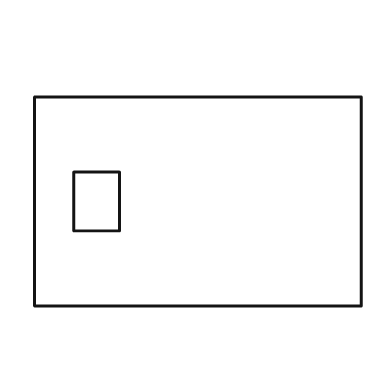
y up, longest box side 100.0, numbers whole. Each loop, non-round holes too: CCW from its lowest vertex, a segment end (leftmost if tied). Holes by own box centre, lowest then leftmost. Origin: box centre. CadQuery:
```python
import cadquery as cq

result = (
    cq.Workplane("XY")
    .moveTo(-50.0, -32.0)
    .lineTo(50.0, -32.0)
    .lineTo(50.0, 32.0)
    .lineTo(-50.0, 32.0)
    .close()
    .moveTo(-38.0, -9.0)
    .lineTo(-24.0, -9.0)
    .lineTo(-24.0, 9.0)
    .lineTo(-38.0, 9.0)
    .close()
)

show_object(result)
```